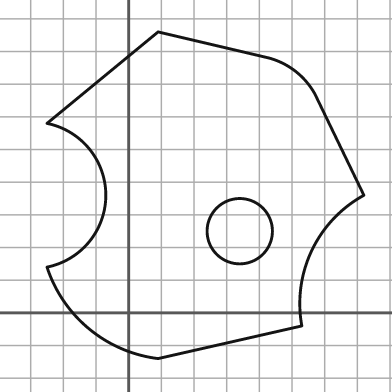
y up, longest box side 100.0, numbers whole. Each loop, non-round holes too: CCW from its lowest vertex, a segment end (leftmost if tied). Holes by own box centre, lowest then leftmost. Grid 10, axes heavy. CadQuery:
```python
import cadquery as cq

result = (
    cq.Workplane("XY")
    .moveTo(9.0, -14.0)
    .lineTo(53.0, -4.0)
    .threePointArc((56.0, 19.0), (72.0, 36.0))
    .lineTo(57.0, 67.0)
    .threePointArc((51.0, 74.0), (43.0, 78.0))
    .lineTo(9.0, 86.0)
    .lineTo(-25.0, 58.0)
    .threePointArc((-7.0, 36.0), (-25.0, 14.0))
    .threePointArc((-12.0, -5.0), (9.0, -14.0))
    .close()
    .moveTo(34.0, 25.0)
    .circle(10.0)
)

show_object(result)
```